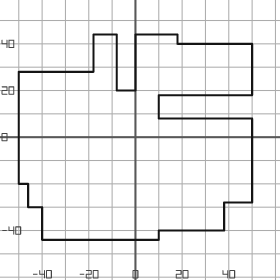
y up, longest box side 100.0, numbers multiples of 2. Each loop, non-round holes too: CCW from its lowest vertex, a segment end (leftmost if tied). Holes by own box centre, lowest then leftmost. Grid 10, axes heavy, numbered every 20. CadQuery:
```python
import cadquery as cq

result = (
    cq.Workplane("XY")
    .moveTo(-40.0, -44.0)
    .lineTo(10.0, -44.0)
    .lineTo(10.0, -40.0)
    .lineTo(38.0, -40.0)
    .lineTo(38.0, -28.0)
    .lineTo(50.0, -28.0)
    .lineTo(50.0, 8.0)
    .lineTo(10.0, 8.0)
    .lineTo(10.0, 18.0)
    .lineTo(50.0, 18.0)
    .lineTo(50.0, 40.0)
    .lineTo(18.0, 40.0)
    .lineTo(18.0, 44.0)
    .lineTo(0.0, 44.0)
    .lineTo(0.0, 20.0)
    .lineTo(-8.0, 20.0)
    .lineTo(-8.0, 44.0)
    .lineTo(-18.0, 44.0)
    .lineTo(-18.0, 28.0)
    .lineTo(-50.0, 28.0)
    .lineTo(-50.0, -20.0)
    .lineTo(-46.0, -20.0)
    .lineTo(-46.0, -30.0)
    .lineTo(-40.0, -30.0)
    .close()
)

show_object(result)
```